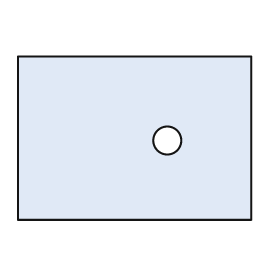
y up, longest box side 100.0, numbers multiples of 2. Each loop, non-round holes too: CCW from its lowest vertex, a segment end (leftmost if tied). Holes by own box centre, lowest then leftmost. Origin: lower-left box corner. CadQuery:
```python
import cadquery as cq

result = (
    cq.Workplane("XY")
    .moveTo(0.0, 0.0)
    .lineTo(100.0, 0.0)
    .lineTo(100.0, 70.0)
    .lineTo(0.0, 70.0)
    .close()
    .moveTo(64.0, 34.0)
    .circle(6.0)
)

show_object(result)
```